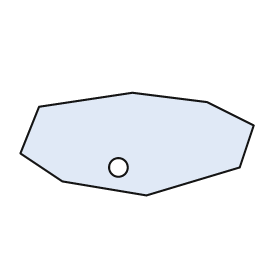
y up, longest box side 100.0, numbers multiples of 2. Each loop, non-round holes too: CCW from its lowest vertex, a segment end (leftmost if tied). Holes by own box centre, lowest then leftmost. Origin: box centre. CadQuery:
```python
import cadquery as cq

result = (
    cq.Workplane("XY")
    .moveTo(4.0, -22.0)
    .lineTo(44.0, -10.0)
    .lineTo(50.0, 8.0)
    .lineTo(30.0, 18.0)
    .lineTo(-2.0, 22.0)
    .lineTo(-42.0, 16.0)
    .lineTo(-50.0, -4.0)
    .lineTo(-32.0, -16.0)
    .close()
    .moveTo(-8.0, -10.0)
    .circle(4.0)
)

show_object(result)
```